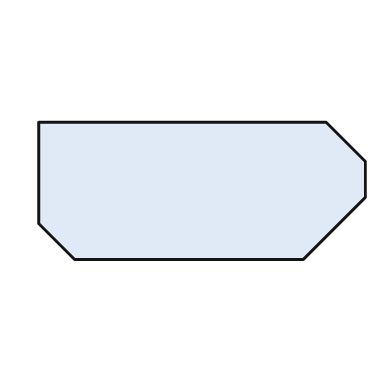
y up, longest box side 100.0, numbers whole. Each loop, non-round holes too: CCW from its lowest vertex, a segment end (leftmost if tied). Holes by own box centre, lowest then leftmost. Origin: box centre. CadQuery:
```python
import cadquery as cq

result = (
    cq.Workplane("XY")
    .moveTo(-39.0, -21.0)
    .lineTo(31.0, -21.0)
    .lineTo(50.0, -2.0)
    .lineTo(50.0, 9.0)
    .lineTo(38.0, 21.0)
    .lineTo(-50.0, 21.0)
    .lineTo(-50.0, -10.0)
    .close()
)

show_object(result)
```